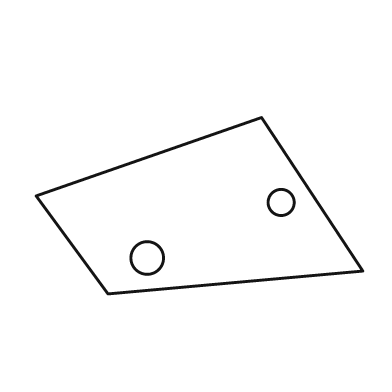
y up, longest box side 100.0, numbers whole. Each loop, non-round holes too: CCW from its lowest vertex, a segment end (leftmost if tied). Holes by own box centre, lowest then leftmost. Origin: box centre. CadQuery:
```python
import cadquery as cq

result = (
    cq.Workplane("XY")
    .moveTo(-28.0, -27.0)
    .lineTo(50.0, -20.0)
    .lineTo(19.0, 27.0)
    .lineTo(-50.0, 3.0)
    .close()
    .moveTo(-16.0, -16.0)
    .circle(5.0)
    .moveTo(25.0, 1.0)
    .circle(4.0)
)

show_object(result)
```